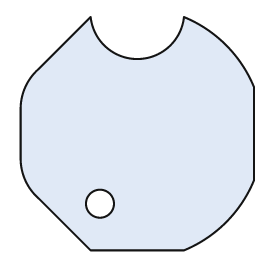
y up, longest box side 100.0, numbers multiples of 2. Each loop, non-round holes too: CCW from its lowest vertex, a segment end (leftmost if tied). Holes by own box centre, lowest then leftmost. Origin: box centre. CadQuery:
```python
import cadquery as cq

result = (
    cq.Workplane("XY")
    .moveTo(-20.0, -50.0)
    .lineTo(20.0, -50.0)
    .threePointArc((38.0, -38.0), (50.0, -20.0))
    .lineTo(50.0, 20.0)
    .threePointArc((38.0, 38.0), (20.0, 50.0))
    .threePointArc((0.0, 32.0), (-20.0, 50.0))
    .lineTo(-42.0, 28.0)
    .threePointArc((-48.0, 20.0), (-50.0, 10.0))
    .lineTo(-50.0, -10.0)
    .threePointArc((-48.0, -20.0), (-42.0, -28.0))
    .close()
    .moveTo(-16.0, -30.0)
    .circle(6.0)
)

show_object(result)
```